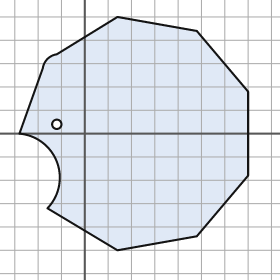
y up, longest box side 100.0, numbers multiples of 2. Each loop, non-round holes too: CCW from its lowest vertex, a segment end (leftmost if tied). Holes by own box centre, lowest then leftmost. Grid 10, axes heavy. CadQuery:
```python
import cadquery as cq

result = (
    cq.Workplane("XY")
    .moveTo(14.0, -50.0)
    .lineTo(48.0, -44.0)
    .lineTo(70.0, -18.0)
    .lineTo(70.0, 18.0)
    .lineTo(48.0, 44.0)
    .lineTo(14.0, 50.0)
    .lineTo(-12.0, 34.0)
    .threePointArc((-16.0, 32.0), (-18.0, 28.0))
    .lineTo(-28.0, 0.0)
    .threePointArc((-12.0, -12.0), (-16.0, -32.0))
    .close()
    .moveTo(-12.0, 4.0)
    .circle(2.0)
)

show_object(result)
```